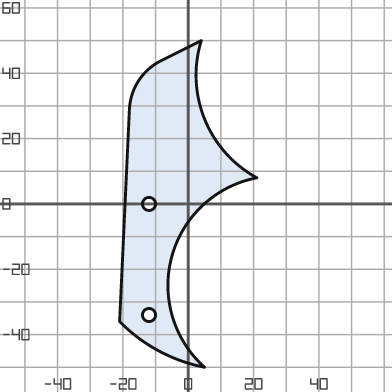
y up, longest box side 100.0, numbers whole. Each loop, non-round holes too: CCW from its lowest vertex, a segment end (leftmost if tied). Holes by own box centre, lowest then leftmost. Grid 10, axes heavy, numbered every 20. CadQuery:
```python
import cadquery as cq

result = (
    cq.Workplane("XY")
    .moveTo(5.0, -50.0)
    .threePointArc((-5.0, -16.0), (21.0, 8.0))
    .threePointArc((5.0, 26.0), (4.0, 50.0))
    .lineTo(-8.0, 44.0)
    .threePointArc((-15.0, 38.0), (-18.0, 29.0))
    .lineTo(-21.0, -36.0)
    .threePointArc((-9.0, -45.0), (5.0, -50.0))
    .close()
    .moveTo(-12.0, -34.0)
    .circle(2.0)
    .moveTo(-12.0, 0.0)
    .circle(2.0)
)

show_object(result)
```